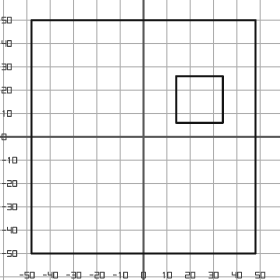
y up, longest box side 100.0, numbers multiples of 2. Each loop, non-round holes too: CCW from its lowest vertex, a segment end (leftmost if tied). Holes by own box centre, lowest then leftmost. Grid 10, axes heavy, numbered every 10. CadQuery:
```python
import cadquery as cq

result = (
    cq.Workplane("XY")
    .moveTo(-48.0, -50.0)
    .lineTo(48.0, -50.0)
    .lineTo(48.0, 50.0)
    .lineTo(-48.0, 50.0)
    .close()
    .moveTo(14.0, 6.0)
    .lineTo(34.0, 6.0)
    .lineTo(34.0, 26.0)
    .lineTo(14.0, 26.0)
    .close()
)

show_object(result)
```